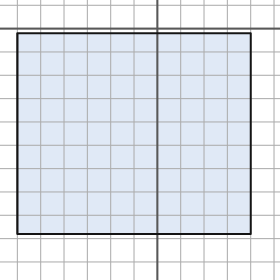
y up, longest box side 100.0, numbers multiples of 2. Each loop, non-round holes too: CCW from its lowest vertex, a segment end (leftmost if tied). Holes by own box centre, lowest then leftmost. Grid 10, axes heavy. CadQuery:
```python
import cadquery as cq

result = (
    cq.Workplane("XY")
    .moveTo(-60.0, -88.0)
    .lineTo(40.0, -88.0)
    .lineTo(40.0, -2.0)
    .lineTo(-60.0, -2.0)
    .close()
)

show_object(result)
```